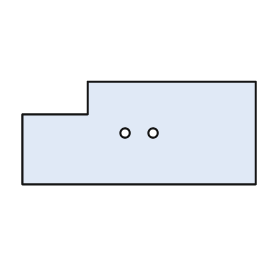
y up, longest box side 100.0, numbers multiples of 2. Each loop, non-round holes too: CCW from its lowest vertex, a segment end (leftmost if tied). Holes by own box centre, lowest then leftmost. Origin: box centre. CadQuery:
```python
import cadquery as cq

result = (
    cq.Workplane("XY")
    .moveTo(-50.0, -22.0)
    .lineTo(50.0, -22.0)
    .lineTo(50.0, 22.0)
    .lineTo(-22.0, 22.0)
    .lineTo(-22.0, 8.0)
    .lineTo(-50.0, 8.0)
    .close()
    .moveTo(-6.0, 0.0)
    .circle(2.0)
    .moveTo(6.0, 0.0)
    .circle(2.0)
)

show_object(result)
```